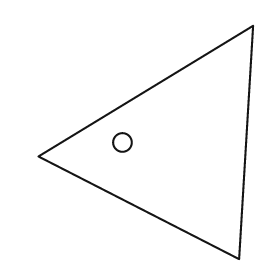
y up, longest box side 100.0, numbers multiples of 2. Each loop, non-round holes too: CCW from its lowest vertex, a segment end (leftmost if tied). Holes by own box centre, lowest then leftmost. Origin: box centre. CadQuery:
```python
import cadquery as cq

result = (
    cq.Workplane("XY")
    .moveTo(40.0, -50.0)
    .lineTo(46.0, 50.0)
    .lineTo(-46.0, -6.0)
    .close()
    .moveTo(-10.0, 0.0)
    .circle(4.0)
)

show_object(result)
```